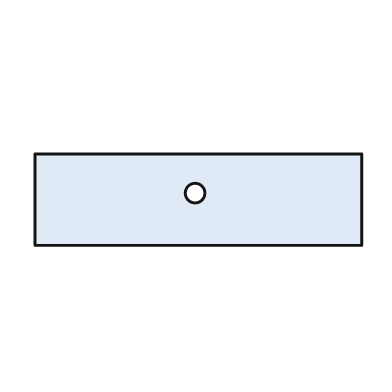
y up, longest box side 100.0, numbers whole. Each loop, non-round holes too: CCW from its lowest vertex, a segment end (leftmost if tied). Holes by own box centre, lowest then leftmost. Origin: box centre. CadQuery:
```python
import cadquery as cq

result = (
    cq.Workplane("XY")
    .moveTo(-50.0, -14.0)
    .lineTo(50.0, -14.0)
    .lineTo(50.0, 14.0)
    .lineTo(-50.0, 14.0)
    .close()
    .moveTo(-1.0, 2.0)
    .circle(3.0)
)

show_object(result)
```